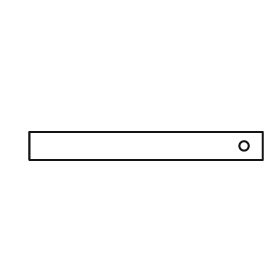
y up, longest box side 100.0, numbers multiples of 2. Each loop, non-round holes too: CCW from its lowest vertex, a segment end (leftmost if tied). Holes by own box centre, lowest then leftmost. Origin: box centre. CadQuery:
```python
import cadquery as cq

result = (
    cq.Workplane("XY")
    .moveTo(-50.0, -6.0)
    .lineTo(50.0, -6.0)
    .lineTo(50.0, 6.0)
    .lineTo(-50.0, 6.0)
    .close()
    .moveTo(42.0, 0.0)
    .circle(2.0)
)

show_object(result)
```